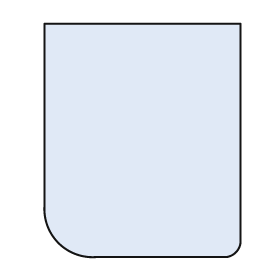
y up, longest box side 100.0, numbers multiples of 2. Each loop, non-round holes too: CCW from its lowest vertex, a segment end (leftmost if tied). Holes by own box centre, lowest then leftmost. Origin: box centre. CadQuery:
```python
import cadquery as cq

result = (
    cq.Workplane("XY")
    .moveTo(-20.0, -50.0)
    .lineTo(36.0, -50.0)
    .threePointArc((40.0, -48.0), (42.0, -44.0))
    .lineTo(42.0, 50.0)
    .lineTo(-42.0, 50.0)
    .lineTo(-42.0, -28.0)
    .threePointArc((-36.0, -44.0), (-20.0, -50.0))
    .close()
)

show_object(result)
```